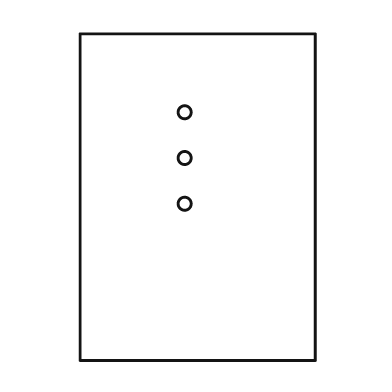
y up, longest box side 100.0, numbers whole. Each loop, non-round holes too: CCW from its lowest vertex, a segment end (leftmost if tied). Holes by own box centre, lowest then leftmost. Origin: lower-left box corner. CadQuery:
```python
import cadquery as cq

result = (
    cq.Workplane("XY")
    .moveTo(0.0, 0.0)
    .lineTo(72.0, 0.0)
    .lineTo(72.0, 100.0)
    .lineTo(0.0, 100.0)
    .close()
    .moveTo(32.0, 48.0)
    .circle(2.0)
    .moveTo(32.0, 62.0)
    .circle(2.0)
    .moveTo(32.0, 76.0)
    .circle(2.0)
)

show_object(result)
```